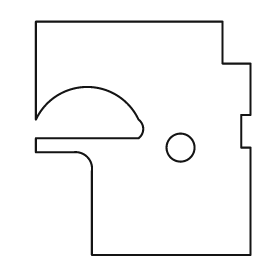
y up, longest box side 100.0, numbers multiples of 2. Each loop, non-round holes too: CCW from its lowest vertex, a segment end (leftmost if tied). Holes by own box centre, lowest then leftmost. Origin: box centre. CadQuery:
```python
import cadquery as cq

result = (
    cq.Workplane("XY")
    .moveTo(-22.0, -50.0)
    .lineTo(46.0, -50.0)
    .lineTo(46.0, -4.0)
    .lineTo(42.0, -4.0)
    .lineTo(42.0, 10.0)
    .lineTo(46.0, 10.0)
    .lineTo(46.0, 32.0)
    .lineTo(34.0, 32.0)
    .lineTo(34.0, 50.0)
    .lineTo(-46.0, 50.0)
    .lineTo(-46.0, 8.0)
    .threePointArc((-24.0, 22.0), (-2.0, 8.0))
    .threePointArc((0.0, 4.0), (-2.0, 0.0))
    .lineTo(-46.0, 0.0)
    .lineTo(-46.0, -6.0)
    .lineTo(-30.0, -6.0)
    .threePointArc((-24.0, -8.0), (-22.0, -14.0))
    .close()
    .moveTo(16.0, -4.0)
    .circle(6.0)
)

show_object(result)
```